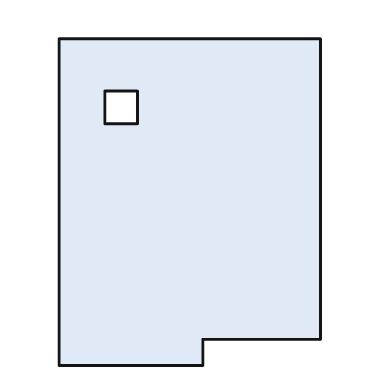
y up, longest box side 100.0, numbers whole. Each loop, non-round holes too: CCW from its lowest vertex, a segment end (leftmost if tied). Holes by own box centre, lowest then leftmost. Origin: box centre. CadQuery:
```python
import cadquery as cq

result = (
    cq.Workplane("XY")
    .moveTo(-40.0, -50.0)
    .lineTo(4.0, -50.0)
    .lineTo(4.0, -42.0)
    .lineTo(40.0, -42.0)
    .lineTo(40.0, 50.0)
    .lineTo(-40.0, 50.0)
    .close()
    .moveTo(-26.0, 24.0)
    .lineTo(-16.0, 24.0)
    .lineTo(-16.0, 34.0)
    .lineTo(-26.0, 34.0)
    .close()
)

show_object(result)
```